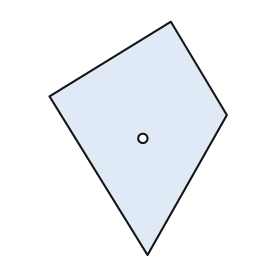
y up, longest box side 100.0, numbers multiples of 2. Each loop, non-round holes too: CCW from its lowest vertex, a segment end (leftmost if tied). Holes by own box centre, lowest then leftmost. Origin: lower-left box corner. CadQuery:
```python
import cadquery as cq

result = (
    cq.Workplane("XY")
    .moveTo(42.0, 0.0)
    .lineTo(76.0, 60.0)
    .lineTo(52.0, 100.0)
    .lineTo(0.0, 68.0)
    .close()
    .moveTo(40.0, 50.0)
    .circle(2.0)
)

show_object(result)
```